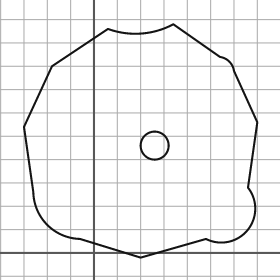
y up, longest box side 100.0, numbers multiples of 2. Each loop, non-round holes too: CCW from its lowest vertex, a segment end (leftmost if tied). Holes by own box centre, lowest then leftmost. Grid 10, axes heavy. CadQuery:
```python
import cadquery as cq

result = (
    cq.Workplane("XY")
    .moveTo(20.0, -2.0)
    .lineTo(48.0, 6.0)
    .threePointArc((66.0, 10.0), (66.0, 28.0))
    .lineTo(70.0, 56.0)
    .lineTo(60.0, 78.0)
    .threePointArc((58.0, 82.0), (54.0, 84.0))
    .lineTo(34.0, 98.0)
    .threePointArc((20.0, 94.0), (6.0, 96.0))
    .lineTo(-18.0, 80.0)
    .lineTo(-30.0, 54.0)
    .lineTo(-26.0, 26.0)
    .threePointArc((-20.0, 12.0), (-6.0, 6.0))
    .close()
    .moveTo(26.0, 46.0)
    .circle(6.0)
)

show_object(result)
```